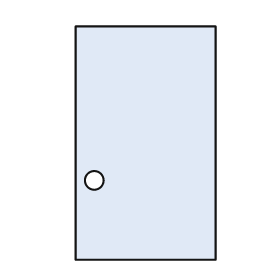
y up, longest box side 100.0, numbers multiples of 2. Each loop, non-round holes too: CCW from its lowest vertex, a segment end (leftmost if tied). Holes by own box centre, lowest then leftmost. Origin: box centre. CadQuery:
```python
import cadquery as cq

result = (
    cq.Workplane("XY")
    .moveTo(-30.0, -50.0)
    .lineTo(30.0, -50.0)
    .lineTo(30.0, 50.0)
    .lineTo(-30.0, 50.0)
    .close()
    .moveTo(-22.0, -16.0)
    .circle(4.0)
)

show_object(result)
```